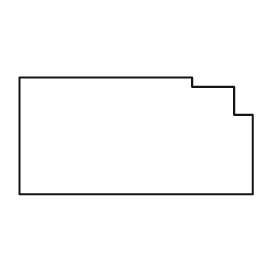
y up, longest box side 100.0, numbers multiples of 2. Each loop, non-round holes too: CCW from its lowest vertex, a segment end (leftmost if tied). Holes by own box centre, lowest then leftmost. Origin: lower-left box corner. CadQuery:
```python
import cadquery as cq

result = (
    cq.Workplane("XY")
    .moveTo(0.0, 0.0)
    .lineTo(100.0, 0.0)
    .lineTo(100.0, 34.0)
    .lineTo(92.0, 34.0)
    .lineTo(92.0, 46.0)
    .lineTo(74.0, 46.0)
    .lineTo(74.0, 50.0)
    .lineTo(0.0, 50.0)
    .close()
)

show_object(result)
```